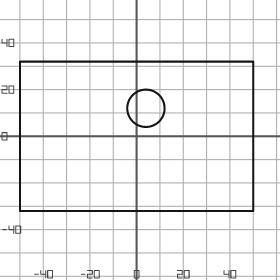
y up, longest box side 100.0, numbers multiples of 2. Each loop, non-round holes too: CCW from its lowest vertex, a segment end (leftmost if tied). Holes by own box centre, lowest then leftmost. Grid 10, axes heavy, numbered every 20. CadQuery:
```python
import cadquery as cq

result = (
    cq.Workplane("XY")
    .moveTo(-50.0, -32.0)
    .lineTo(50.0, -32.0)
    .lineTo(50.0, 32.0)
    .lineTo(-50.0, 32.0)
    .close()
    .moveTo(4.0, 12.0)
    .circle(8.0)
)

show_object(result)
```